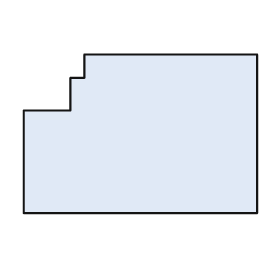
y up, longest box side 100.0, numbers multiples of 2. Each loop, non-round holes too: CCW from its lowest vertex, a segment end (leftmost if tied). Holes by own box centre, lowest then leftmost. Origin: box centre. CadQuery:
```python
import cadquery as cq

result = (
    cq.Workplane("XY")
    .moveTo(-50.0, -34.0)
    .lineTo(50.0, -34.0)
    .lineTo(50.0, 34.0)
    .lineTo(-24.0, 34.0)
    .lineTo(-24.0, 24.0)
    .lineTo(-30.0, 24.0)
    .lineTo(-30.0, 10.0)
    .lineTo(-50.0, 10.0)
    .close()
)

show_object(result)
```